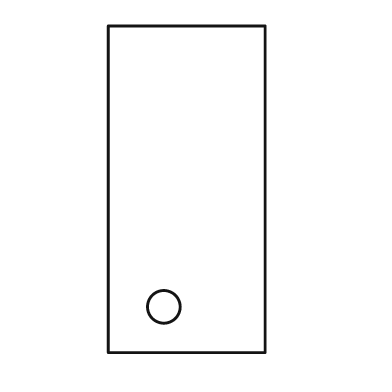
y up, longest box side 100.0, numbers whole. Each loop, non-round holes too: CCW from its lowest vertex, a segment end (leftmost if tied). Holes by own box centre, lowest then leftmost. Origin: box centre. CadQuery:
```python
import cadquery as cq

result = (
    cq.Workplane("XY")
    .moveTo(-24.0, -50.0)
    .lineTo(24.0, -50.0)
    .lineTo(24.0, 50.0)
    .lineTo(-24.0, 50.0)
    .close()
    .moveTo(-7.0, -36.0)
    .circle(5.0)
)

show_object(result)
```